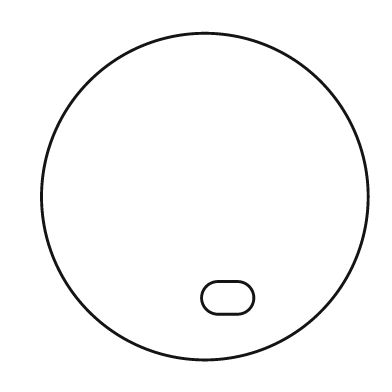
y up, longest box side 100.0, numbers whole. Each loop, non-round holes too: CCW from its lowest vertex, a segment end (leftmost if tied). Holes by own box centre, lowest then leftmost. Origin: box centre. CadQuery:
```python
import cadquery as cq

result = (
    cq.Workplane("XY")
    .moveTo(0.0, 0.0)
    .circle(50.0)
    .moveTo(4.0, -36.0)
    .lineTo(10.0, -36.0)
    .threePointArc((15.0, -31.0), (10.0, -26.0))
    .lineTo(4.0, -26.0)
    .threePointArc((-1.0, -31.0), (4.0, -36.0))
    .close()
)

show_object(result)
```